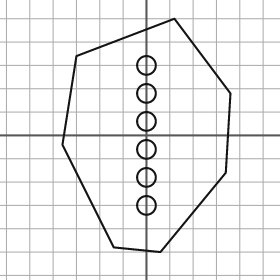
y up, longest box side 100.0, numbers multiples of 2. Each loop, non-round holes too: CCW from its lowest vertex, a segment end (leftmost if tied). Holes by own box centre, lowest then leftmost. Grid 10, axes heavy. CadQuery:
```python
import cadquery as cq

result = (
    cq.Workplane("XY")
    .moveTo(6.0, -50.0)
    .lineTo(34.0, -16.0)
    .lineTo(36.0, 18.0)
    .lineTo(12.0, 50.0)
    .lineTo(-30.0, 34.0)
    .lineTo(-36.0, -4.0)
    .lineTo(-14.0, -48.0)
    .close()
    .moveTo(0.0, -30.0)
    .circle(4.0)
    .moveTo(0.0, -18.0)
    .circle(4.0)
    .moveTo(0.0, -6.0)
    .circle(4.0)
    .moveTo(0.0, 6.0)
    .circle(4.0)
    .moveTo(0.0, 18.0)
    .circle(4.0)
    .moveTo(0.0, 30.0)
    .circle(4.0)
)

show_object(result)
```